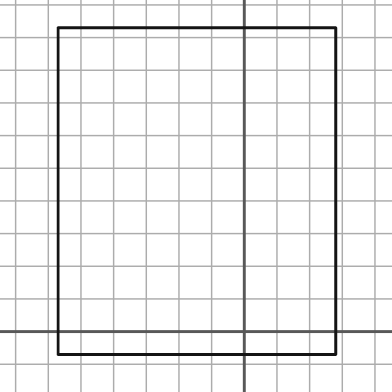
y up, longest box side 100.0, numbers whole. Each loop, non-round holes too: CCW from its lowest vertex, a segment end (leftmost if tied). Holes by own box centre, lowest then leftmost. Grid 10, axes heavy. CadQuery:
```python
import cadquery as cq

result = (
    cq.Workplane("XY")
    .moveTo(-57.0, -7.0)
    .lineTo(28.0, -7.0)
    .lineTo(28.0, 93.0)
    .lineTo(-57.0, 93.0)
    .close()
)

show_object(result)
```